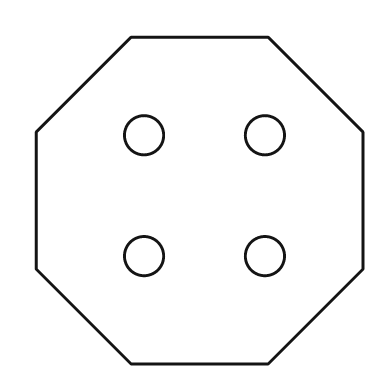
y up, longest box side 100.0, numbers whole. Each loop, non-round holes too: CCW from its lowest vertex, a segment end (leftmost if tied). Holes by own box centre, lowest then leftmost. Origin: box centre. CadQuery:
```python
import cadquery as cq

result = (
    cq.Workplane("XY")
    .moveTo(-21.0, -50.0)
    .lineTo(21.0, -50.0)
    .lineTo(50.0, -21.0)
    .lineTo(50.0, 21.0)
    .lineTo(21.0, 50.0)
    .lineTo(-21.0, 50.0)
    .lineTo(-50.0, 21.0)
    .lineTo(-50.0, -21.0)
    .close()
    .moveTo(-17.0, -17.0)
    .circle(6.0)
    .moveTo(20.0, -17.0)
    .circle(6.0)
    .moveTo(-17.0, 20.0)
    .circle(6.0)
    .moveTo(20.0, 20.0)
    .circle(6.0)
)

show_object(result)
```